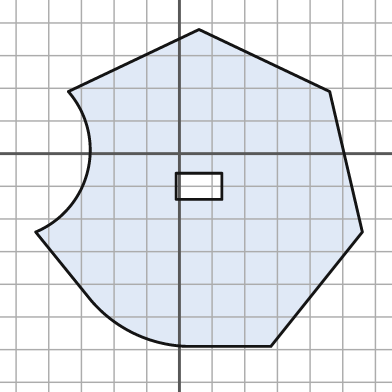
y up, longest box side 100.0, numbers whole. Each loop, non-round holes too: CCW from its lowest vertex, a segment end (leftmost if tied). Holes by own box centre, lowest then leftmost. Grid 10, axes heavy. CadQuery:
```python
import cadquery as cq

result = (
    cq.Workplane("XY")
    .moveTo(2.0, -59.0)
    .lineTo(28.0, -59.0)
    .lineTo(56.0, -24.0)
    .lineTo(46.0, 19.0)
    .lineTo(6.0, 38.0)
    .lineTo(-34.0, 19.0)
    .threePointArc((-28.0, -5.0), (-44.0, -24.0))
    .lineTo(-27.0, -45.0)
    .threePointArc((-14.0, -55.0), (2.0, -59.0))
    .close()
    .moveTo(-1.0, -14.0)
    .lineTo(13.0, -14.0)
    .lineTo(13.0, -6.0)
    .lineTo(-1.0, -6.0)
    .close()
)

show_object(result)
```